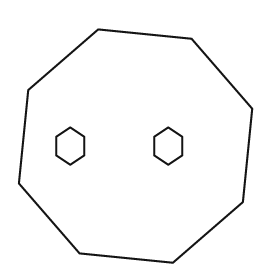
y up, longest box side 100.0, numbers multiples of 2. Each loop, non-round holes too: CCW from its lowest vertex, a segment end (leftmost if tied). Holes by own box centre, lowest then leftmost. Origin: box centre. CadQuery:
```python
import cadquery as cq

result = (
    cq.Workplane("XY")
    .moveTo(16.0, -50.0)
    .lineTo(46.0, -24.0)
    .lineTo(50.0, 16.0)
    .lineTo(24.0, 46.0)
    .lineTo(-16.0, 50.0)
    .lineTo(-46.0, 24.0)
    .lineTo(-50.0, -16.0)
    .lineTo(-24.0, -46.0)
    .close()
    .moveTo(-28.0, -8.0)
    .lineTo(-22.0, -4.0)
    .lineTo(-22.0, 4.0)
    .lineTo(-28.0, 8.0)
    .lineTo(-34.0, 4.0)
    .lineTo(-34.0, -4.0)
    .close()
    .moveTo(14.0, -8.0)
    .lineTo(20.0, -4.0)
    .lineTo(20.0, 4.0)
    .lineTo(14.0, 8.0)
    .lineTo(8.0, 4.0)
    .lineTo(8.0, -4.0)
    .close()
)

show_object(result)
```